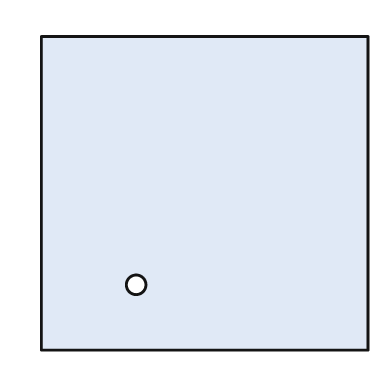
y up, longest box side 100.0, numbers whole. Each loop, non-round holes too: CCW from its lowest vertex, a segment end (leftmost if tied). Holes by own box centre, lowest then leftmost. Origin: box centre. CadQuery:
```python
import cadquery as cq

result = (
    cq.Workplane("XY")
    .moveTo(-50.0, -48.0)
    .lineTo(50.0, -48.0)
    .lineTo(50.0, 48.0)
    .lineTo(-50.0, 48.0)
    .close()
    .moveTo(-21.0, -28.0)
    .circle(3.0)
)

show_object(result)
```